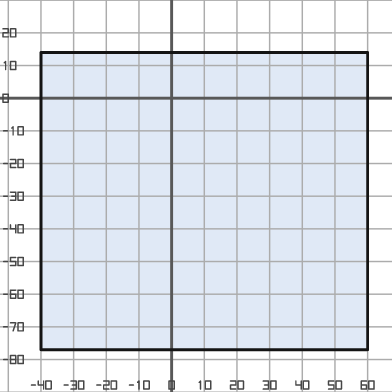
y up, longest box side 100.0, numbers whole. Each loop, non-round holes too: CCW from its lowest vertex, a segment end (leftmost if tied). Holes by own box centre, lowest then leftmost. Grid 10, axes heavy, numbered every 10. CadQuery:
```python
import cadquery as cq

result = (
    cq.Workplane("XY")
    .moveTo(-40.0, -77.0)
    .lineTo(60.0, -77.0)
    .lineTo(60.0, 14.0)
    .lineTo(-40.0, 14.0)
    .close()
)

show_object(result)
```